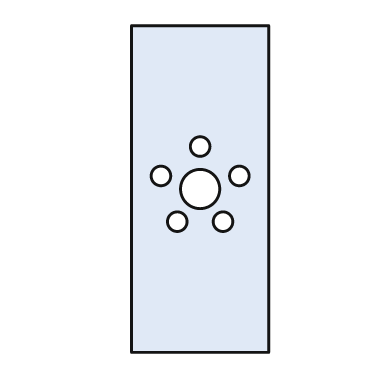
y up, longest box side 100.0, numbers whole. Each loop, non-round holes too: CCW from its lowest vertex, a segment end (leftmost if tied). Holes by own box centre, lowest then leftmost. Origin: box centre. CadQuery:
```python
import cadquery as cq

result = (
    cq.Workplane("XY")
    .moveTo(-21.0, -50.0)
    .lineTo(21.0, -50.0)
    .lineTo(21.0, 50.0)
    .lineTo(-21.0, 50.0)
    .close()
    .moveTo(-7.0, -10.0)
    .circle(3.0)
    .moveTo(7.0, -10.0)
    .circle(3.0)
    .moveTo(0.0, 0.0)
    .circle(6.0)
    .moveTo(-12.0, 4.0)
    .circle(3.0)
    .moveTo(12.0, 4.0)
    .circle(3.0)
    .moveTo(0.0, 13.0)
    .circle(3.0)
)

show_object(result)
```